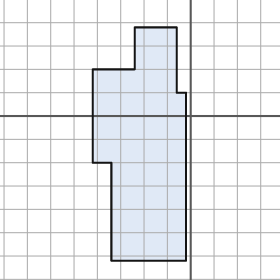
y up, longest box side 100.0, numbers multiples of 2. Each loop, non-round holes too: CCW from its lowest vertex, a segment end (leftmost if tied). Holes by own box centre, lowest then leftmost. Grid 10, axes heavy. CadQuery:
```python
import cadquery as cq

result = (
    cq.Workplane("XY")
    .moveTo(-34.0, -62.0)
    .lineTo(-2.0, -62.0)
    .lineTo(-2.0, 10.0)
    .lineTo(-6.0, 10.0)
    .lineTo(-6.0, 38.0)
    .lineTo(-24.0, 38.0)
    .lineTo(-24.0, 20.0)
    .lineTo(-42.0, 20.0)
    .lineTo(-42.0, -20.0)
    .lineTo(-34.0, -20.0)
    .close()
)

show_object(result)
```